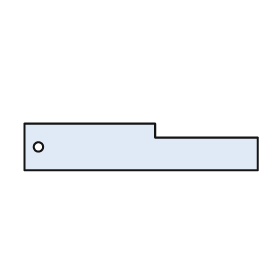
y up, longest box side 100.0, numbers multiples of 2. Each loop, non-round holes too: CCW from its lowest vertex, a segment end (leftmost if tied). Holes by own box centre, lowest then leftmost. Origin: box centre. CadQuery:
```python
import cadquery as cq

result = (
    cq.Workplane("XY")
    .moveTo(-50.0, -10.0)
    .lineTo(50.0, -10.0)
    .lineTo(50.0, 4.0)
    .lineTo(6.0, 4.0)
    .lineTo(6.0, 10.0)
    .lineTo(-50.0, 10.0)
    .close()
    .moveTo(-44.0, 0.0)
    .circle(2.0)
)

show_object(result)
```